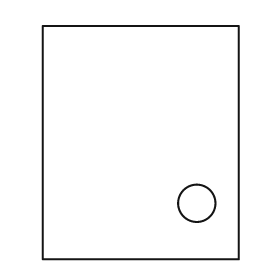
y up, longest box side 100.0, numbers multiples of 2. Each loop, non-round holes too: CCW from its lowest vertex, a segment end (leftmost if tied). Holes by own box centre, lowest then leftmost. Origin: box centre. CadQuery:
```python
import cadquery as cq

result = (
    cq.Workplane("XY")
    .moveTo(-42.0, -50.0)
    .lineTo(42.0, -50.0)
    .lineTo(42.0, 50.0)
    .lineTo(-42.0, 50.0)
    .close()
    .moveTo(24.0, -26.0)
    .circle(8.0)
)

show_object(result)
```